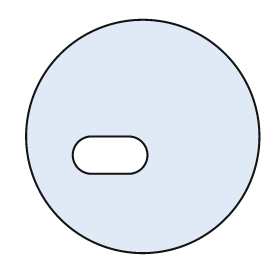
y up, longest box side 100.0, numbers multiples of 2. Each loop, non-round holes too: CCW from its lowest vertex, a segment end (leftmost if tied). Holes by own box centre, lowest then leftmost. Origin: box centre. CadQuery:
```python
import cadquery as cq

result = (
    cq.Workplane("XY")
    .moveTo(0.0, 0.0)
    .circle(50.0)
    .moveTo(-22.0, -16.0)
    .lineTo(-6.0, -16.0)
    .threePointArc((2.0, -8.0), (-6.0, 0.0))
    .lineTo(-22.0, 0.0)
    .threePointArc((-30.0, -8.0), (-22.0, -16.0))
    .close()
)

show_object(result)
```